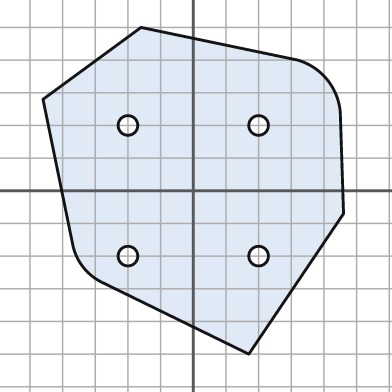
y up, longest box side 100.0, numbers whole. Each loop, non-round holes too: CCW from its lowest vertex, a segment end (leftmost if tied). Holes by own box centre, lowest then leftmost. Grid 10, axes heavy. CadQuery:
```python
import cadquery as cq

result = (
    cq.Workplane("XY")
    .moveTo(17.0, -50.0)
    .lineTo(46.0, -7.0)
    .lineTo(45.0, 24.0)
    .threePointArc((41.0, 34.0), (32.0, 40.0))
    .lineTo(-16.0, 50.0)
    .lineTo(-46.0, 28.0)
    .lineTo(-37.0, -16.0)
    .threePointArc((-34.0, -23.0), (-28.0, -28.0))
    .close()
    .moveTo(-20.0, -20.0)
    .circle(3.0)
    .moveTo(20.0, -20.0)
    .circle(3.0)
    .moveTo(-20.0, 20.0)
    .circle(3.0)
    .moveTo(20.0, 20.0)
    .circle(3.0)
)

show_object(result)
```